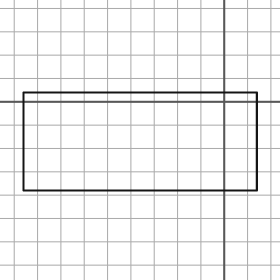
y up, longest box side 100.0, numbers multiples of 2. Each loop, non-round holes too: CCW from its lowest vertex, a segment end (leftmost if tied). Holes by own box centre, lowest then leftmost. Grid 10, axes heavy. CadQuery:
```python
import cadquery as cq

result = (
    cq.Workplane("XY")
    .moveTo(-86.0, -38.0)
    .lineTo(14.0, -38.0)
    .lineTo(14.0, 4.0)
    .lineTo(-86.0, 4.0)
    .close()
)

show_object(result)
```